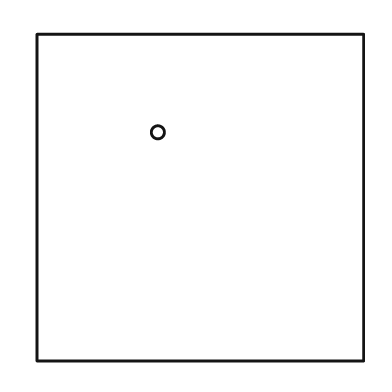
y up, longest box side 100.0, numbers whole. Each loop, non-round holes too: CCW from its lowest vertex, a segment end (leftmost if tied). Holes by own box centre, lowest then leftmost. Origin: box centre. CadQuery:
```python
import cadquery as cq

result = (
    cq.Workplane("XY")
    .moveTo(-50.0, -50.0)
    .lineTo(50.0, -50.0)
    .lineTo(50.0, 50.0)
    .lineTo(-50.0, 50.0)
    .close()
    .moveTo(-13.0, 20.0)
    .circle(2.0)
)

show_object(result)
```